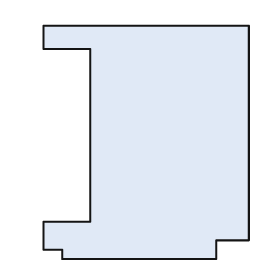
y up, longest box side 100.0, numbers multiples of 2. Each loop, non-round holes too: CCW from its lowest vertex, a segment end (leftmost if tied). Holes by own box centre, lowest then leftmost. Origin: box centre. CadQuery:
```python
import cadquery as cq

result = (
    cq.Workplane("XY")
    .moveTo(-36.0, -50.0)
    .lineTo(30.0, -50.0)
    .lineTo(30.0, -42.0)
    .lineTo(44.0, -42.0)
    .lineTo(44.0, 50.0)
    .lineTo(-44.0, 50.0)
    .lineTo(-44.0, 40.0)
    .lineTo(-24.0, 40.0)
    .lineTo(-24.0, -34.0)
    .lineTo(-44.0, -34.0)
    .lineTo(-44.0, -46.0)
    .lineTo(-36.0, -46.0)
    .close()
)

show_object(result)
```